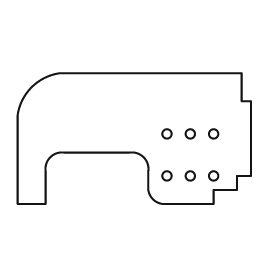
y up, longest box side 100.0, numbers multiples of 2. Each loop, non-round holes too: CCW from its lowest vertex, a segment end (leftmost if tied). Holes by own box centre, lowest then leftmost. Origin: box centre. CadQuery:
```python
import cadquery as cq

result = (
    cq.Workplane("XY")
    .moveTo(-50.0, -28.0)
    .lineTo(-38.0, -28.0)
    .lineTo(-38.0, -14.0)
    .threePointArc((-36.0, -8.0), (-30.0, -6.0))
    .lineTo(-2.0, -6.0)
    .threePointArc((4.0, -8.0), (6.0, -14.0))
    .lineTo(6.0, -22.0)
    .threePointArc((8.0, -26.0), (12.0, -28.0))
    .lineTo(34.0, -28.0)
    .lineTo(34.0, -22.0)
    .lineTo(44.0, -22.0)
    .lineTo(44.0, -16.0)
    .lineTo(50.0, -16.0)
    .lineTo(50.0, 16.0)
    .lineTo(46.0, 16.0)
    .lineTo(46.0, 28.0)
    .lineTo(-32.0, 28.0)
    .threePointArc((-44.0, 22.0), (-50.0, 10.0))
    .close()
    .moveTo(14.0, -16.0)
    .circle(2.0)
    .moveTo(24.0, -16.0)
    .circle(2.0)
    .moveTo(34.0, -16.0)
    .circle(2.0)
    .moveTo(14.0, 2.0)
    .circle(2.0)
    .moveTo(24.0, 2.0)
    .circle(2.0)
    .moveTo(34.0, 2.0)
    .circle(2.0)
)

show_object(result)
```